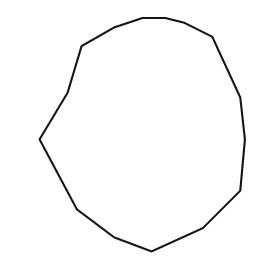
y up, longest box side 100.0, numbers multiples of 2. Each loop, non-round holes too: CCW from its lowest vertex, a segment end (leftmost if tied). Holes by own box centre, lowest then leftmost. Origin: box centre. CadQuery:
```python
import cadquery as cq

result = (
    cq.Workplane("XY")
    .moveTo(4.0, -50.0)
    .lineTo(26.0, -40.0)
    .lineTo(42.0, -24.0)
    .lineTo(44.0, -2.0)
    .lineTo(42.0, 16.0)
    .lineTo(30.0, 42.0)
    .lineTo(18.0, 48.0)
    .lineTo(10.0, 50.0)
    .lineTo(0.0, 50.0)
    .lineTo(-12.0, 46.0)
    .lineTo(-26.0, 38.0)
    .lineTo(-32.0, 18.0)
    .lineTo(-44.0, -2.0)
    .lineTo(-28.0, -32.0)
    .lineTo(-12.0, -44.0)
    .close()
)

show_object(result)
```